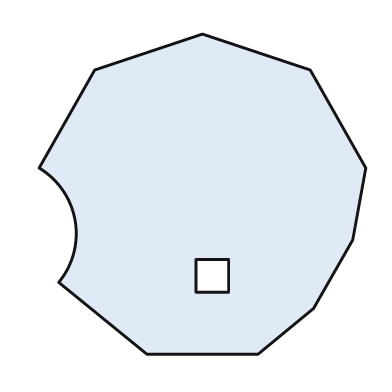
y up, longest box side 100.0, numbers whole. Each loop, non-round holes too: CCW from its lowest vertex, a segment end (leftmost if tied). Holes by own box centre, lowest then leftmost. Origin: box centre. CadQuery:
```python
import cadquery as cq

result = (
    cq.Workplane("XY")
    .moveTo(-17.0, -49.0)
    .lineTo(17.0, -49.0)
    .lineTo(34.0, -35.0)
    .lineTo(46.0, -14.0)
    .lineTo(50.0, 8.0)
    .lineTo(33.0, 38.0)
    .lineTo(0.0, 49.0)
    .lineTo(-33.0, 38.0)
    .lineTo(-50.0, 8.0)
    .threePointArc((-39.0, -8.0), (-44.0, -27.0))
    .close()
    .moveTo(-2.0, -30.0)
    .lineTo(8.0, -30.0)
    .lineTo(8.0, -20.0)
    .lineTo(-2.0, -20.0)
    .close()
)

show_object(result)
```